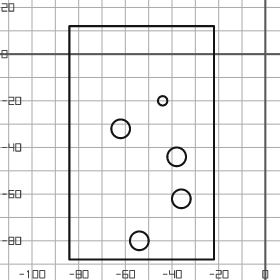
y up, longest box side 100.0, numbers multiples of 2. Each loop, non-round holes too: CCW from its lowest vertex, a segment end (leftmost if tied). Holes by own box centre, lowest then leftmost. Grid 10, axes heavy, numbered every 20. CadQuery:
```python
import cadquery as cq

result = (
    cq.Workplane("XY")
    .moveTo(-84.0, -88.0)
    .lineTo(-22.0, -88.0)
    .lineTo(-22.0, 12.0)
    .lineTo(-84.0, 12.0)
    .close()
    .moveTo(-54.0, -80.0)
    .circle(4.0)
    .moveTo(-36.0, -62.0)
    .circle(4.0)
    .moveTo(-38.0, -44.0)
    .circle(4.0)
    .moveTo(-62.0, -32.0)
    .circle(4.0)
    .moveTo(-44.0, -20.0)
    .circle(2.0)
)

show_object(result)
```